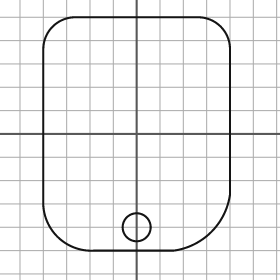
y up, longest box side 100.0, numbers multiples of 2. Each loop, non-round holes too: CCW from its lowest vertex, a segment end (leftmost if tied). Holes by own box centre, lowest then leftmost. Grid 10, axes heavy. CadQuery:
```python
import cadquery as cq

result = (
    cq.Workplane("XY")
    .moveTo(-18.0, -50.0)
    .lineTo(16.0, -50.0)
    .threePointArc((32.0, -42.0), (40.0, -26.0))
    .lineTo(40.0, 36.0)
    .threePointArc((36.0, 46.0), (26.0, 50.0))
    .lineTo(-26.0, 50.0)
    .threePointArc((-36.0, 46.0), (-40.0, 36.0))
    .lineTo(-40.0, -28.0)
    .threePointArc((-34.0, -44.0), (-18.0, -50.0))
    .close()
    .moveTo(0.0, -40.0)
    .circle(6.0)
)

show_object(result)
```